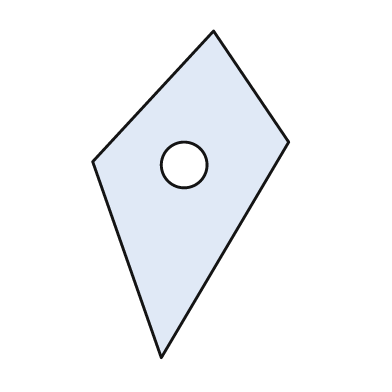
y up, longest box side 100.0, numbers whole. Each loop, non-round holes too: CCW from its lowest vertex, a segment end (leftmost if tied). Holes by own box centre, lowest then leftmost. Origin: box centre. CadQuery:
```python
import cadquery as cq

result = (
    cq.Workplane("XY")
    .moveTo(-9.0, -50.0)
    .lineTo(30.0, 16.0)
    .lineTo(7.0, 50.0)
    .lineTo(-30.0, 10.0)
    .close()
    .moveTo(-2.0, 9.0)
    .circle(7.0)
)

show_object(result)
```